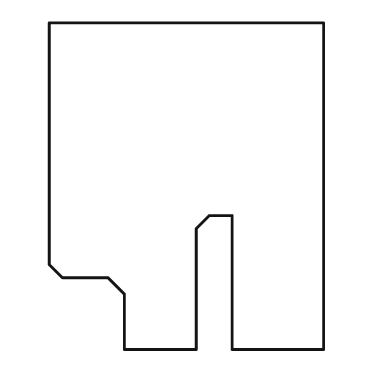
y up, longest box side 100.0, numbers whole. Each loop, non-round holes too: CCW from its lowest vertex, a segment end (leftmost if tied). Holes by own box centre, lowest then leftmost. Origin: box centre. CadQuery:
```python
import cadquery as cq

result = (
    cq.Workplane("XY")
    .moveTo(-19.0, -50.0)
    .lineTo(3.0, -50.0)
    .lineTo(3.0, -13.0)
    .lineTo(7.0, -9.0)
    .lineTo(14.0, -9.0)
    .lineTo(14.0, -50.0)
    .lineTo(42.0, -50.0)
    .lineTo(42.0, 50.0)
    .lineTo(-42.0, 50.0)
    .lineTo(-42.0, -24.0)
    .lineTo(-38.0, -28.0)
    .lineTo(-24.0, -28.0)
    .lineTo(-19.0, -33.0)
    .close()
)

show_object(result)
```